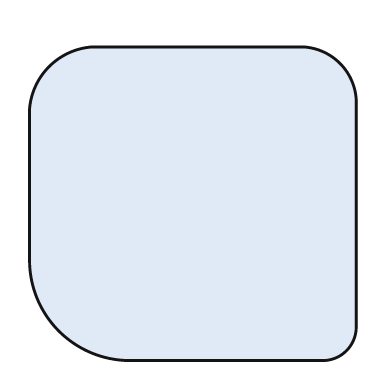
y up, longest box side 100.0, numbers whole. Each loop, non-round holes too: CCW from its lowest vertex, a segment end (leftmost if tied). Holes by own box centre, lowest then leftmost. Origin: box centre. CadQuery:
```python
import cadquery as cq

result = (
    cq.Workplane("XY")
    .moveTo(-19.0, -48.0)
    .lineTo(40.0, -48.0)
    .threePointArc((47.0, -45.0), (50.0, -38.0))
    .lineTo(50.0, 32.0)
    .threePointArc((45.0, 43.0), (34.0, 48.0))
    .lineTo(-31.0, 48.0)
    .threePointArc((-44.0, 42.0), (-50.0, 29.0))
    .lineTo(-50.0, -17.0)
    .threePointArc((-41.0, -39.0), (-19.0, -48.0))
    .close()
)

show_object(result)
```